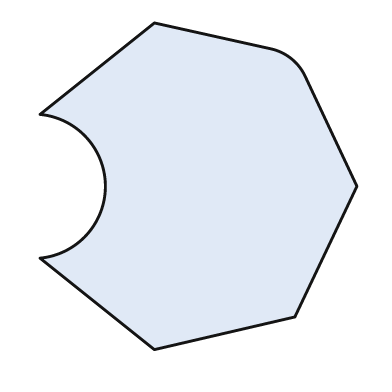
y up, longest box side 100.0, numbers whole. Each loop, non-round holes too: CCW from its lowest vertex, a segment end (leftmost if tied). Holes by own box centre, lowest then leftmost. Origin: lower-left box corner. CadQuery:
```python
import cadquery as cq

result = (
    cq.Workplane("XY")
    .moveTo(35.0, 0.0)
    .lineTo(78.0, 10.0)
    .lineTo(97.0, 50.0)
    .lineTo(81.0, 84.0)
    .threePointArc((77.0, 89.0), (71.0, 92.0))
    .lineTo(35.0, 100.0)
    .lineTo(0.0, 72.0)
    .threePointArc((20.0, 50.0), (0.0, 28.0))
    .close()
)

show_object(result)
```